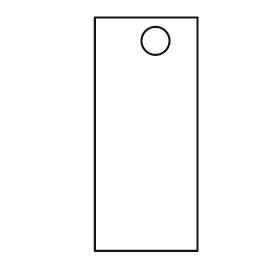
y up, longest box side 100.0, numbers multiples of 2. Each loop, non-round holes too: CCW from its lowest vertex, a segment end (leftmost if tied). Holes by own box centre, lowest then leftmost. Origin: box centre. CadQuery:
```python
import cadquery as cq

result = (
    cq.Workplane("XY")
    .moveTo(-22.0, -50.0)
    .lineTo(22.0, -50.0)
    .lineTo(22.0, 50.0)
    .lineTo(-22.0, 50.0)
    .close()
    .moveTo(4.0, 40.0)
    .circle(6.0)
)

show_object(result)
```